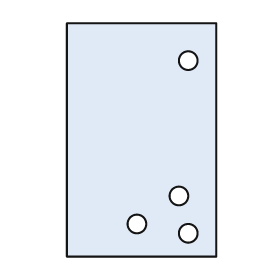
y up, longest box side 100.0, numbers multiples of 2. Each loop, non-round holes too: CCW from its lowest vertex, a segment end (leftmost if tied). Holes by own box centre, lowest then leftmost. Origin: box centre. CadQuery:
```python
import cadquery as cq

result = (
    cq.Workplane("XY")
    .moveTo(-32.0, -50.0)
    .lineTo(32.0, -50.0)
    .lineTo(32.0, 50.0)
    .lineTo(-32.0, 50.0)
    .close()
    .moveTo(20.0, -40.0)
    .circle(4.0)
    .moveTo(-2.0, -36.0)
    .circle(4.0)
    .moveTo(16.0, -24.0)
    .circle(4.0)
    .moveTo(20.0, 34.0)
    .circle(4.0)
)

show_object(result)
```